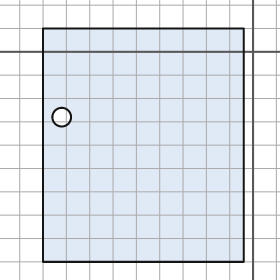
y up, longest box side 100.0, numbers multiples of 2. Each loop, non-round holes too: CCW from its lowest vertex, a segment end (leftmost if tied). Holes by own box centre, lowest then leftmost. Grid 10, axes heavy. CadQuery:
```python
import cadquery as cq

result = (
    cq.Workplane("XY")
    .moveTo(-90.0, -90.0)
    .lineTo(-4.0, -90.0)
    .lineTo(-4.0, 10.0)
    .lineTo(-90.0, 10.0)
    .close()
    .moveTo(-82.0, -28.0)
    .circle(4.0)
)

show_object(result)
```